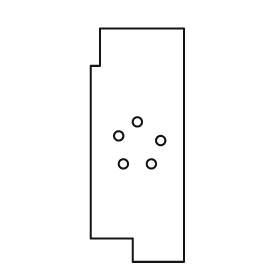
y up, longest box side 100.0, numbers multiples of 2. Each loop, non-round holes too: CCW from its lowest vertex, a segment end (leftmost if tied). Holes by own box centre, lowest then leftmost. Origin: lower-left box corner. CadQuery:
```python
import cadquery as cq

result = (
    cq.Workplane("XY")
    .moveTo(18.0, 0.0)
    .lineTo(40.0, 0.0)
    .lineTo(40.0, 100.0)
    .lineTo(4.0, 100.0)
    .lineTo(4.0, 84.0)
    .lineTo(0.0, 84.0)
    .lineTo(0.0, 10.0)
    .lineTo(18.0, 10.0)
    .close()
    .moveTo(14.0, 42.0)
    .circle(2.0)
    .moveTo(26.0, 42.0)
    .circle(2.0)
    .moveTo(30.0, 52.0)
    .circle(2.0)
    .moveTo(12.0, 54.0)
    .circle(2.0)
    .moveTo(20.0, 60.0)
    .circle(2.0)
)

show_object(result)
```